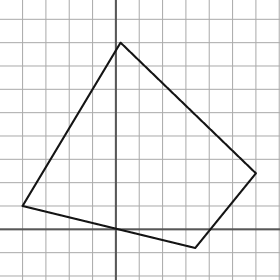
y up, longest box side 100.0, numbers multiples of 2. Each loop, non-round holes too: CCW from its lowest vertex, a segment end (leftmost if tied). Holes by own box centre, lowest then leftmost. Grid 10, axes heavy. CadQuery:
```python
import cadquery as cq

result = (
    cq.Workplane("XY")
    .moveTo(34.0, -8.0)
    .lineTo(60.0, 24.0)
    .lineTo(2.0, 80.0)
    .lineTo(-40.0, 10.0)
    .close()
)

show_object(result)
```